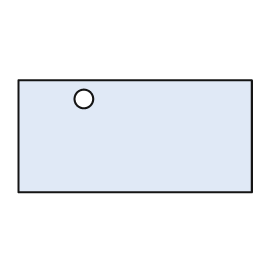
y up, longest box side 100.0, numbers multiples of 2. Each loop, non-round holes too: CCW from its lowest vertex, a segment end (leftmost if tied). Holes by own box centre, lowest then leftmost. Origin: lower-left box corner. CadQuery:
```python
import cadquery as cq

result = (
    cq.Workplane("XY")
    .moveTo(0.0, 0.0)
    .lineTo(100.0, 0.0)
    .lineTo(100.0, 48.0)
    .lineTo(0.0, 48.0)
    .close()
    .moveTo(28.0, 40.0)
    .circle(4.0)
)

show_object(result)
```